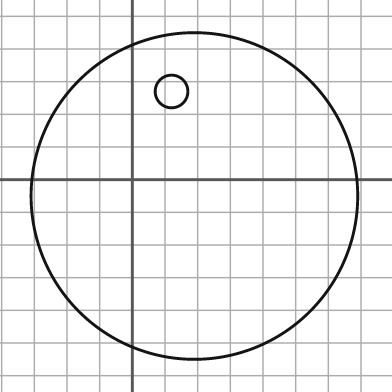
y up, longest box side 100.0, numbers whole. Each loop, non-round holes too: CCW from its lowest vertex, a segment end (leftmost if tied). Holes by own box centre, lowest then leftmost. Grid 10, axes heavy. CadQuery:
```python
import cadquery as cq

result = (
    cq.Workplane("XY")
    .moveTo(19.0, -5.0)
    .circle(50.0)
    .moveTo(12.0, 27.0)
    .circle(5.0)
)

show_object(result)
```